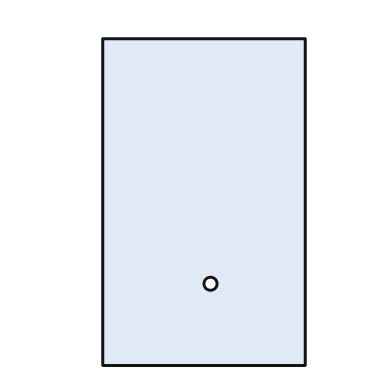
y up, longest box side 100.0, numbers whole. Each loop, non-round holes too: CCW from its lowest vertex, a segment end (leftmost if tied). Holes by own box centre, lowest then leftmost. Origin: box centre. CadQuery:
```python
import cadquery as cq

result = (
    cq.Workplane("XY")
    .moveTo(-31.0, -50.0)
    .lineTo(31.0, -50.0)
    .lineTo(31.0, 50.0)
    .lineTo(-31.0, 50.0)
    .close()
    .moveTo(2.0, -25.0)
    .circle(2.0)
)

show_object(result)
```